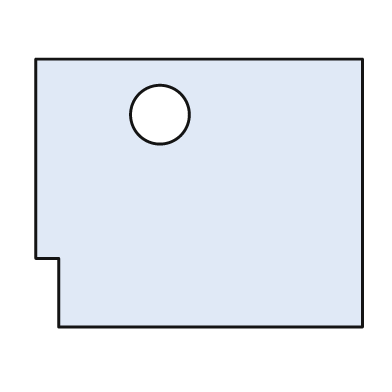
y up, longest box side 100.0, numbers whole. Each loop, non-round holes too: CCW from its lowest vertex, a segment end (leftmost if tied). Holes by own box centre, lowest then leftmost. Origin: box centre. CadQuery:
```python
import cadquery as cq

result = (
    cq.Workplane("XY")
    .moveTo(-43.0, -41.0)
    .lineTo(50.0, -41.0)
    .lineTo(50.0, 41.0)
    .lineTo(-50.0, 41.0)
    .lineTo(-50.0, -20.0)
    .lineTo(-43.0, -20.0)
    .close()
    .moveTo(-12.0, 24.0)
    .circle(9.0)
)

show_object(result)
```